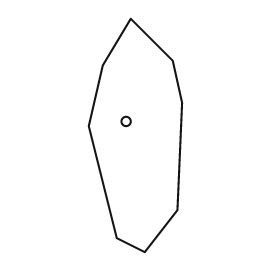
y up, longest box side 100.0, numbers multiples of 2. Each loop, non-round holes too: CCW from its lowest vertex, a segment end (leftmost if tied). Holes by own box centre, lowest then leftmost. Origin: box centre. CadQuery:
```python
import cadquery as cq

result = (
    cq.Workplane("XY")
    .moveTo(4.0, -50.0)
    .lineTo(18.0, -32.0)
    .lineTo(20.0, 14.0)
    .lineTo(16.0, 32.0)
    .lineTo(-2.0, 50.0)
    .lineTo(-14.0, 30.0)
    .lineTo(-20.0, 4.0)
    .lineTo(-8.0, -44.0)
    .close()
    .moveTo(-4.0, 6.0)
    .circle(2.0)
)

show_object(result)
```